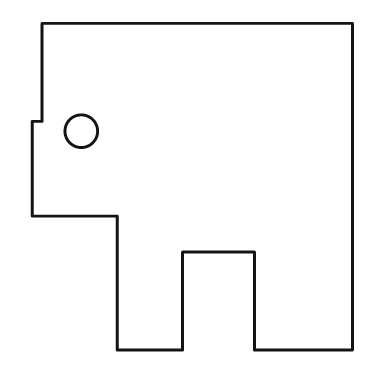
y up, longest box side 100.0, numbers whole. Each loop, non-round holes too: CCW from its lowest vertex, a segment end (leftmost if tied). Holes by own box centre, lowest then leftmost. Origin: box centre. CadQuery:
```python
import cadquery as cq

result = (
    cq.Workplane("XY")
    .moveTo(-23.0, -50.0)
    .lineTo(-3.0, -50.0)
    .lineTo(-3.0, -20.0)
    .lineTo(19.0, -20.0)
    .lineTo(19.0, -50.0)
    .lineTo(49.0, -50.0)
    .lineTo(49.0, 50.0)
    .lineTo(-46.0, 50.0)
    .lineTo(-46.0, 20.0)
    .lineTo(-49.0, 20.0)
    .lineTo(-49.0, -9.0)
    .lineTo(-23.0, -9.0)
    .close()
    .moveTo(-34.0, 17.0)
    .circle(5.0)
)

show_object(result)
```